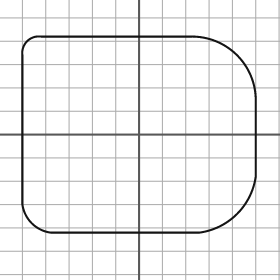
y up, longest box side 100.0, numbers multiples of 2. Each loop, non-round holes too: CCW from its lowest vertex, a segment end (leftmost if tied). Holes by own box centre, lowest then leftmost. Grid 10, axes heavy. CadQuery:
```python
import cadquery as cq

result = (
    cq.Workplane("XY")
    .moveTo(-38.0, -42.0)
    .lineTo(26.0, -42.0)
    .threePointArc((42.0, -34.0), (50.0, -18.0))
    .lineTo(50.0, 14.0)
    .threePointArc((42.0, 34.0), (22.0, 42.0))
    .lineTo(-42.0, 42.0)
    .threePointArc((-48.0, 40.0), (-50.0, 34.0))
    .lineTo(-50.0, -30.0)
    .threePointArc((-46.0, -38.0), (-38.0, -42.0))
    .close()
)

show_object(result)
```